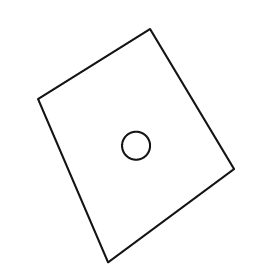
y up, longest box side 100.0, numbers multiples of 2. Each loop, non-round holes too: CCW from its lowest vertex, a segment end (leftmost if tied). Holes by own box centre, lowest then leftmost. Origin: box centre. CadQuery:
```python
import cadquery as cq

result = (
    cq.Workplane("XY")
    .moveTo(-12.0, -50.0)
    .lineTo(42.0, -10.0)
    .lineTo(6.0, 50.0)
    .lineTo(-42.0, 20.0)
    .close()
    .moveTo(0.0, 0.0)
    .circle(6.0)
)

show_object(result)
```